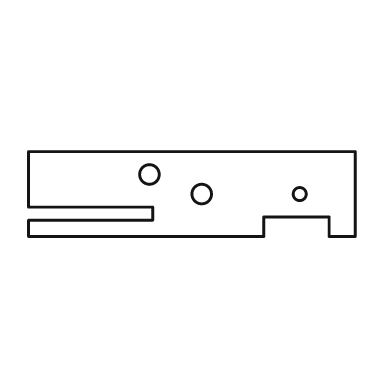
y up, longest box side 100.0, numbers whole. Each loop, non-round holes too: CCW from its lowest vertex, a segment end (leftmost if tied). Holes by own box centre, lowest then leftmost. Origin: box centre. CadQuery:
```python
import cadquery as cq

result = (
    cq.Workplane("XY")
    .moveTo(-50.0, -13.0)
    .lineTo(22.0, -13.0)
    .lineTo(22.0, -7.0)
    .lineTo(42.0, -7.0)
    .lineTo(42.0, -13.0)
    .lineTo(50.0, -13.0)
    .lineTo(50.0, 13.0)
    .lineTo(-50.0, 13.0)
    .lineTo(-50.0, -4.0)
    .lineTo(-12.0, -4.0)
    .lineTo(-12.0, -8.0)
    .lineTo(-50.0, -8.0)
    .close()
    .moveTo(3.0, 0.0)
    .circle(3.0)
    .moveTo(33.0, 0.0)
    .circle(2.0)
    .moveTo(-13.0, 6.0)
    .circle(3.0)
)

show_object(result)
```